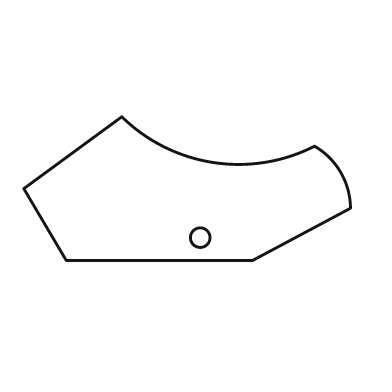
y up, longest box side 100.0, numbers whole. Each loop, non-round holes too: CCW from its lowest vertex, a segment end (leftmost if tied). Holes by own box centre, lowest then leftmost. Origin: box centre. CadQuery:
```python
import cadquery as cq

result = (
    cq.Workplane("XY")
    .moveTo(-37.0, -22.0)
    .lineTo(20.0, -22.0)
    .lineTo(50.0, -6.0)
    .threePointArc((47.0, 5.0), (39.0, 13.0))
    .threePointArc((8.0, 8.0), (-20.0, 22.0))
    .lineTo(-50.0, 0.0)
    .close()
    .moveTo(4.0, -15.0)
    .circle(3.0)
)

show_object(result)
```